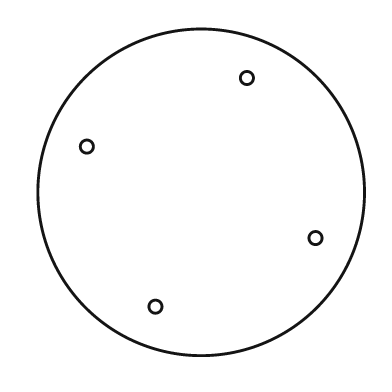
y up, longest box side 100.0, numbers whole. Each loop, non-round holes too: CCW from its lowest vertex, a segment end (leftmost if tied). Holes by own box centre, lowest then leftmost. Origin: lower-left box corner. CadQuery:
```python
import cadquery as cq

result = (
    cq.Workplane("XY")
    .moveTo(50.0, 50.0)
    .circle(50.0)
    .moveTo(36.0, 15.0)
    .circle(2.0)
    .moveTo(85.0, 36.0)
    .circle(2.0)
    .moveTo(15.0, 64.0)
    .circle(2.0)
    .moveTo(64.0, 85.0)
    .circle(2.0)
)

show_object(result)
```